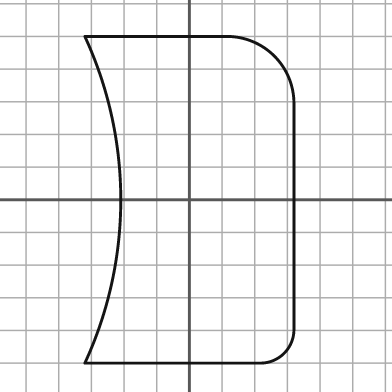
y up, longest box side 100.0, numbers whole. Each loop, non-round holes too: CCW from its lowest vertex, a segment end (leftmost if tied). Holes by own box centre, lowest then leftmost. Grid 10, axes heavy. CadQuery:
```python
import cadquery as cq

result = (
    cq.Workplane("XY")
    .moveTo(-32.0, -50.0)
    .lineTo(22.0, -50.0)
    .threePointArc((29.0, -47.0), (32.0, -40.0))
    .lineTo(32.0, 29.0)
    .threePointArc((26.0, 44.0), (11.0, 50.0))
    .lineTo(-32.0, 50.0)
    .threePointArc((-21.0, 0.0), (-32.0, -50.0))
    .close()
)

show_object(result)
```